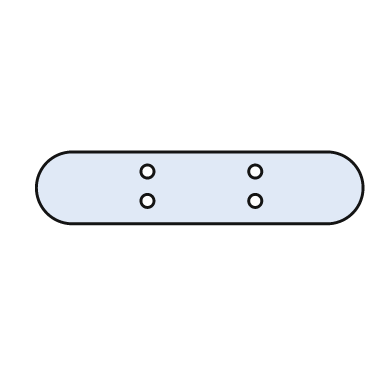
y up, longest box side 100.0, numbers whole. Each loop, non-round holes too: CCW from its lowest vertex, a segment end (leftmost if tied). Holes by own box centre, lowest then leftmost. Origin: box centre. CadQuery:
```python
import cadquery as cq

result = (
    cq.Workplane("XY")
    .moveTo(-39.0, -11.0)
    .lineTo(39.0, -11.0)
    .threePointArc((50.0, 0.0), (39.0, 11.0))
    .lineTo(-39.0, 11.0)
    .threePointArc((-50.0, 0.0), (-39.0, -11.0))
    .close()
    .moveTo(-16.0, -4.0)
    .circle(2.0)
    .moveTo(17.0, -4.0)
    .circle(2.0)
    .moveTo(-16.0, 5.0)
    .circle(2.0)
    .moveTo(17.0, 5.0)
    .circle(2.0)
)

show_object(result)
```